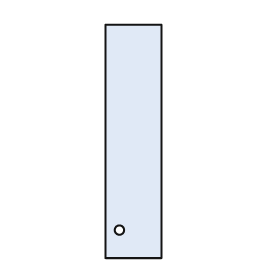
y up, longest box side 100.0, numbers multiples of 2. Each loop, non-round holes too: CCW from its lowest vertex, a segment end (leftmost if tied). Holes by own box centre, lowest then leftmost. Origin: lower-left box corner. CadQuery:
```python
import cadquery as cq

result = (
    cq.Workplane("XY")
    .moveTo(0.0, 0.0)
    .lineTo(24.0, 0.0)
    .lineTo(24.0, 100.0)
    .lineTo(0.0, 100.0)
    .close()
    .moveTo(6.0, 12.0)
    .circle(2.0)
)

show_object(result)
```